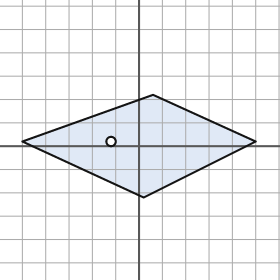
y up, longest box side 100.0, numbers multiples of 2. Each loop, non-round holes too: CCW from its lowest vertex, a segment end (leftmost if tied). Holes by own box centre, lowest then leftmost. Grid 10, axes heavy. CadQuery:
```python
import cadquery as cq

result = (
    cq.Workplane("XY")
    .moveTo(2.0, -22.0)
    .lineTo(50.0, 2.0)
    .lineTo(6.0, 22.0)
    .lineTo(-50.0, 2.0)
    .close()
    .moveTo(-12.0, 2.0)
    .circle(2.0)
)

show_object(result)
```